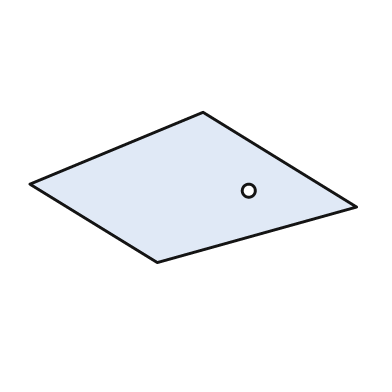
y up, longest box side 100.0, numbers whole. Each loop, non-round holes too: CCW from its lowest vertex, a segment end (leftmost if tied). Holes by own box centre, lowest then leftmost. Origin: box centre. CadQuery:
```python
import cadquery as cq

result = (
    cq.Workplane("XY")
    .moveTo(-11.0, -23.0)
    .lineTo(50.0, -6.0)
    .lineTo(3.0, 23.0)
    .lineTo(-50.0, 1.0)
    .close()
    .moveTo(17.0, -1.0)
    .circle(2.0)
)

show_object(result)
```